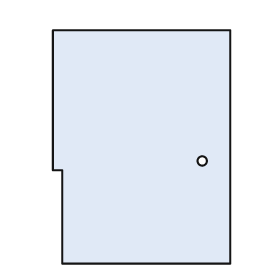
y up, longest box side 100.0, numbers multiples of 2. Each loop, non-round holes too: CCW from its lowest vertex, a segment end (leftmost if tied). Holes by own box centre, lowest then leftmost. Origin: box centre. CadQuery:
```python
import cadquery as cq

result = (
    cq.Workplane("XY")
    .moveTo(-34.0, -50.0)
    .lineTo(38.0, -50.0)
    .lineTo(38.0, 50.0)
    .lineTo(-38.0, 50.0)
    .lineTo(-38.0, -10.0)
    .lineTo(-34.0, -10.0)
    .close()
    .moveTo(26.0, -6.0)
    .circle(2.0)
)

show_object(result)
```